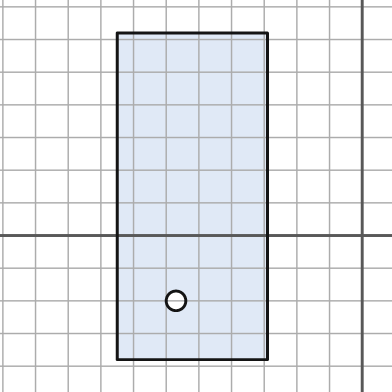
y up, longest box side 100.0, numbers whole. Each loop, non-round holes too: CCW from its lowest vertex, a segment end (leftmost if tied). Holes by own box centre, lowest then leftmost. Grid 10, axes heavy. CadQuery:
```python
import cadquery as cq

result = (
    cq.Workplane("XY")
    .moveTo(-75.0, -38.0)
    .lineTo(-29.0, -38.0)
    .lineTo(-29.0, 62.0)
    .lineTo(-75.0, 62.0)
    .close()
    .moveTo(-57.0, -20.0)
    .circle(3.0)
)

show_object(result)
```